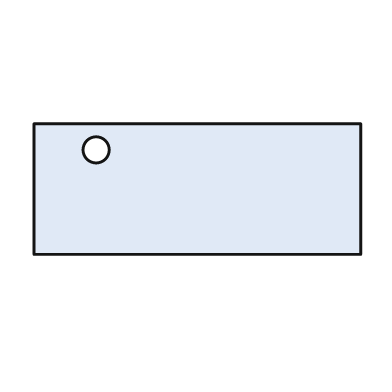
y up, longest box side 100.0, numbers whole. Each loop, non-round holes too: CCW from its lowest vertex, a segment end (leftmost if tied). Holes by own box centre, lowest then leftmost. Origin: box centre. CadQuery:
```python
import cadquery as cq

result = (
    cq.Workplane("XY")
    .moveTo(-50.0, -20.0)
    .lineTo(50.0, -20.0)
    .lineTo(50.0, 20.0)
    .lineTo(-50.0, 20.0)
    .close()
    .moveTo(-31.0, 12.0)
    .circle(4.0)
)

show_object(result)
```